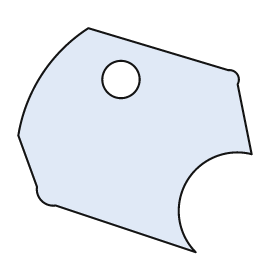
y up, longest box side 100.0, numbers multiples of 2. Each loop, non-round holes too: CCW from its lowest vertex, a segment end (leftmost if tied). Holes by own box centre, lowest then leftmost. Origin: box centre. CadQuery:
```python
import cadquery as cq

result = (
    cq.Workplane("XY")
    .moveTo(26.0, -48.0)
    .threePointArc((22.0, -18.0), (50.0, -6.0))
    .lineTo(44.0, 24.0)
    .threePointArc((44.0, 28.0), (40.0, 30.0))
    .lineTo(-20.0, 48.0)
    .threePointArc((-40.0, 28.0), (-50.0, 2.0))
    .lineTo(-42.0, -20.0)
    .threePointArc((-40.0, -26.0), (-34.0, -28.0))
    .close()
    .moveTo(-6.0, 26.0)
    .circle(8.0)
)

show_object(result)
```